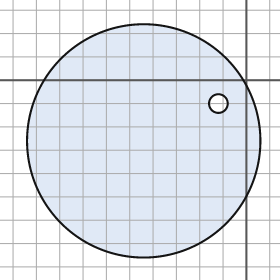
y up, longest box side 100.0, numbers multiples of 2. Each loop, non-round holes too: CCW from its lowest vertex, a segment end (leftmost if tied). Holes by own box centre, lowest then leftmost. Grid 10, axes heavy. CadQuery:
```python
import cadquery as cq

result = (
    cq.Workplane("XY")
    .moveTo(-44.0, -26.0)
    .circle(50.0)
    .moveTo(-12.0, -10.0)
    .circle(4.0)
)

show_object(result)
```